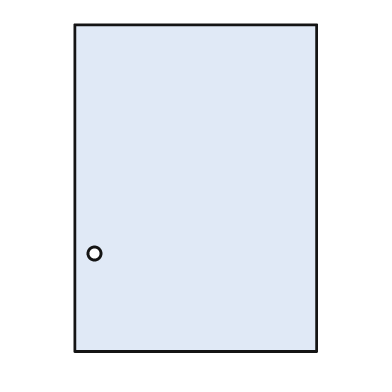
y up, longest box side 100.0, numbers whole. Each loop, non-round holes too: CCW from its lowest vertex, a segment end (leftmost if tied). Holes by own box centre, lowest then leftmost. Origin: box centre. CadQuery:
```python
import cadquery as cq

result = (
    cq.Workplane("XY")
    .moveTo(-37.0, -50.0)
    .lineTo(37.0, -50.0)
    .lineTo(37.0, 50.0)
    .lineTo(-37.0, 50.0)
    .close()
    .moveTo(-31.0, -20.0)
    .circle(2.0)
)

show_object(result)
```